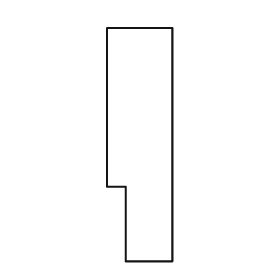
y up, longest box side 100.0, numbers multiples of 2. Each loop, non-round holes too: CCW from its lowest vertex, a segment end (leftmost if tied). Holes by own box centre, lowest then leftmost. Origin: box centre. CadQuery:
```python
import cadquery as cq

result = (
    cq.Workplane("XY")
    .moveTo(-6.0, -50.0)
    .lineTo(14.0, -50.0)
    .lineTo(14.0, 50.0)
    .lineTo(-14.0, 50.0)
    .lineTo(-14.0, -18.0)
    .lineTo(-6.0, -18.0)
    .close()
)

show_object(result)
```